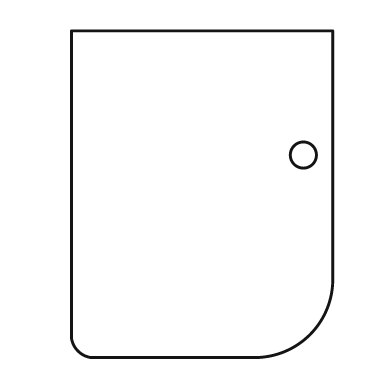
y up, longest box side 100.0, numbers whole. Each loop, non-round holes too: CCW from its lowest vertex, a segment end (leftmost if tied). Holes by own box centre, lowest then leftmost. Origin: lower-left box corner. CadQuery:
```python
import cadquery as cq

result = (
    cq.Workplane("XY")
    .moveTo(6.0, 0.0)
    .lineTo(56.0, 0.0)
    .threePointArc((73.0, 7.0), (80.0, 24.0))
    .lineTo(80.0, 100.0)
    .lineTo(0.0, 100.0)
    .lineTo(0.0, 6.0)
    .threePointArc((2.0, 2.0), (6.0, 0.0))
    .close()
    .moveTo(71.0, 62.0)
    .circle(4.0)
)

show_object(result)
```